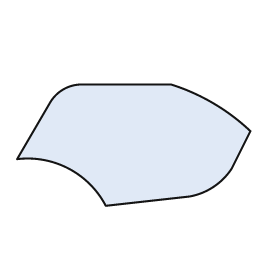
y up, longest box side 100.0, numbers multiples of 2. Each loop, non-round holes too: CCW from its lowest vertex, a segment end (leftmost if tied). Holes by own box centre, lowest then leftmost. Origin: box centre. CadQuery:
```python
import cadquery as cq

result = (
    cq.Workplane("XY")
    .moveTo(-12.0, -26.0)
    .lineTo(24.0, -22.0)
    .threePointArc((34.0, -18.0), (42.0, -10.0))
    .lineTo(50.0, 6.0)
    .threePointArc((34.0, 18.0), (16.0, 26.0))
    .lineTo(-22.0, 26.0)
    .threePointArc((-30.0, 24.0), (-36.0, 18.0))
    .lineTo(-50.0, -6.0)
    .threePointArc((-28.0, -10.0), (-12.0, -26.0))
    .close()
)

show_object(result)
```